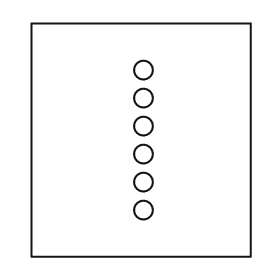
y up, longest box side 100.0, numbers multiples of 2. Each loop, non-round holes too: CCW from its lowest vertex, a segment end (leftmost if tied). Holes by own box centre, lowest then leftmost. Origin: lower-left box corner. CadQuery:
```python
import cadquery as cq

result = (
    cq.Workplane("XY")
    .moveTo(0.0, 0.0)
    .lineTo(94.0, 0.0)
    .lineTo(94.0, 100.0)
    .lineTo(0.0, 100.0)
    .close()
    .moveTo(48.0, 20.0)
    .circle(4.0)
    .moveTo(48.0, 32.0)
    .circle(4.0)
    .moveTo(48.0, 44.0)
    .circle(4.0)
    .moveTo(48.0, 56.0)
    .circle(4.0)
    .moveTo(48.0, 68.0)
    .circle(4.0)
    .moveTo(48.0, 80.0)
    .circle(4.0)
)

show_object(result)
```